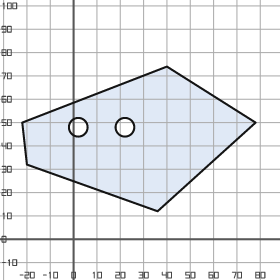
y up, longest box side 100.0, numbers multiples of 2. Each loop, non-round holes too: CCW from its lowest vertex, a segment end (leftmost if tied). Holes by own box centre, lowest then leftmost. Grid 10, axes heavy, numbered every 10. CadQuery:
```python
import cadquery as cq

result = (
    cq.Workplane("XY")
    .moveTo(36.0, 12.0)
    .lineTo(78.0, 50.0)
    .lineTo(40.0, 74.0)
    .lineTo(-22.0, 50.0)
    .lineTo(-20.0, 32.0)
    .close()
    .moveTo(2.0, 48.0)
    .circle(4.0)
    .moveTo(22.0, 48.0)
    .circle(4.0)
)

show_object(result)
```